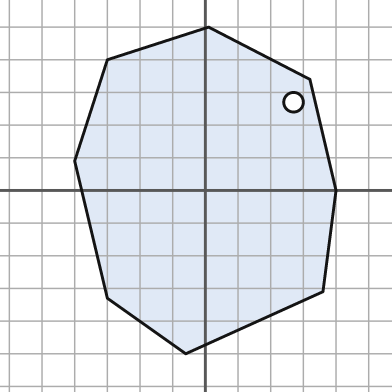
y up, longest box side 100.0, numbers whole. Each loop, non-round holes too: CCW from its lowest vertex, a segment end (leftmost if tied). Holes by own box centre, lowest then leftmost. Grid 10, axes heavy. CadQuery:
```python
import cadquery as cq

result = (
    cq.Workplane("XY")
    .moveTo(-6.0, -50.0)
    .lineTo(36.0, -31.0)
    .lineTo(40.0, 0.0)
    .lineTo(32.0, 34.0)
    .lineTo(1.0, 50.0)
    .lineTo(-30.0, 40.0)
    .lineTo(-40.0, 9.0)
    .lineTo(-30.0, -33.0)
    .close()
    .moveTo(27.0, 27.0)
    .circle(3.0)
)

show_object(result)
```